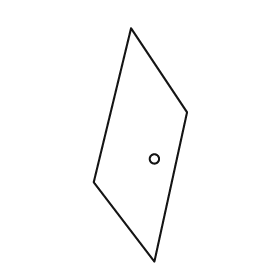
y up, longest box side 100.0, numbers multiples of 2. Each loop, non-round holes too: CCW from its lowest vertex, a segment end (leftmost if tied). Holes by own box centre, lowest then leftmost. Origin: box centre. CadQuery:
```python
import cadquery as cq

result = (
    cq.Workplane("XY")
    .moveTo(6.0, -50.0)
    .lineTo(20.0, 14.0)
    .lineTo(-4.0, 50.0)
    .lineTo(-20.0, -16.0)
    .close()
    .moveTo(6.0, -6.0)
    .circle(2.0)
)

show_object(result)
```